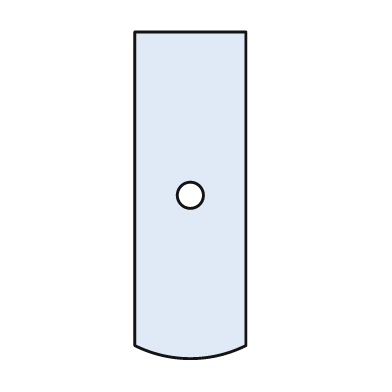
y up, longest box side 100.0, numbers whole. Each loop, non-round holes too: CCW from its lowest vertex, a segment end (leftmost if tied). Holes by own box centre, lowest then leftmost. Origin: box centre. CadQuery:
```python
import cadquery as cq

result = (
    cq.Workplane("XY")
    .moveTo(-17.0, -46.0)
    .threePointArc((0.0, -50.0), (17.0, -46.0))
    .lineTo(17.0, 50.0)
    .lineTo(-17.0, 50.0)
    .close()
    .moveTo(0.0, 0.0)
    .circle(4.0)
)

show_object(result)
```